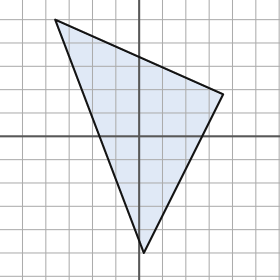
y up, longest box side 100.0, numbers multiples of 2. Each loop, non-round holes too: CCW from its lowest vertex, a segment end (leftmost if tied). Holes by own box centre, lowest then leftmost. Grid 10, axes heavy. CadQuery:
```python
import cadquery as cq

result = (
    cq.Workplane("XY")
    .moveTo(2.0, -50.0)
    .lineTo(36.0, 18.0)
    .lineTo(-36.0, 50.0)
    .close()
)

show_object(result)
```